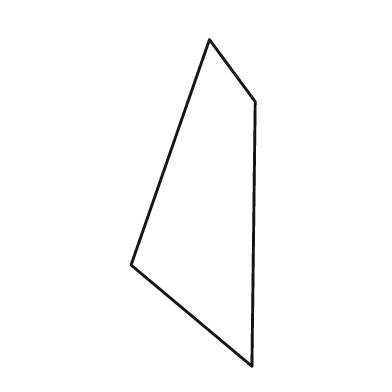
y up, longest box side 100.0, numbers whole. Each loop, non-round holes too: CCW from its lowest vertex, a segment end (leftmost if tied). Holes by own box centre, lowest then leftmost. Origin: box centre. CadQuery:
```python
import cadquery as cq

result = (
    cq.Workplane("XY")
    .moveTo(18.0, -50.0)
    .lineTo(19.0, 31.0)
    .lineTo(5.0, 50.0)
    .lineTo(-19.0, -19.0)
    .close()
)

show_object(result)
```